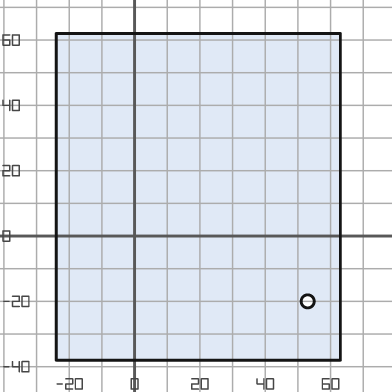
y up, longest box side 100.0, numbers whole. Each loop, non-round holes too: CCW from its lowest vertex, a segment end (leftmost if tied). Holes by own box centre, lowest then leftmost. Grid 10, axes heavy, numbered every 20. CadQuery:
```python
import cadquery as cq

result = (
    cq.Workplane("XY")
    .moveTo(-24.0, -38.0)
    .lineTo(63.0, -38.0)
    .lineTo(63.0, 62.0)
    .lineTo(-24.0, 62.0)
    .close()
    .moveTo(53.0, -20.0)
    .circle(2.0)
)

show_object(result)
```